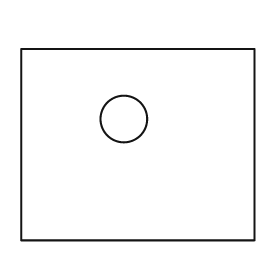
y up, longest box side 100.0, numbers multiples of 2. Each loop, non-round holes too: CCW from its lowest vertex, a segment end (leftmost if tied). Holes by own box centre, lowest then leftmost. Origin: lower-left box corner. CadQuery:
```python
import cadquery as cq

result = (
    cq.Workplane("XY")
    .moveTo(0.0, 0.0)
    .lineTo(100.0, 0.0)
    .lineTo(100.0, 82.0)
    .lineTo(0.0, 82.0)
    .close()
    .moveTo(44.0, 52.0)
    .circle(10.0)
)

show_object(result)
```